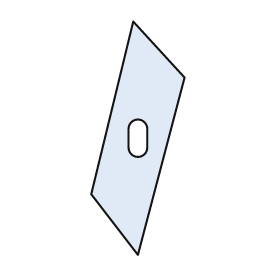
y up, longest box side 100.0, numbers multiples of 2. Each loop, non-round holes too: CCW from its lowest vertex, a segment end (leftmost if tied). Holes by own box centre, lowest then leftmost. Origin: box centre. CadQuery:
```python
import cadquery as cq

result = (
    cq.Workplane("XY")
    .moveTo(0.0, -50.0)
    .lineTo(20.0, 26.0)
    .lineTo(-2.0, 50.0)
    .lineTo(-20.0, -24.0)
    .close()
    .moveTo(-4.0, -4.0)
    .threePointArc((0.0, -8.0), (4.0, -4.0))
    .lineTo(4.0, 4.0)
    .threePointArc((0.0, 8.0), (-4.0, 4.0))
    .close()
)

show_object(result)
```